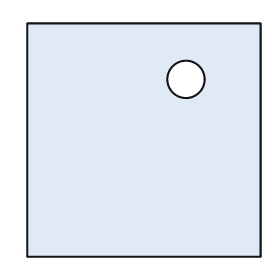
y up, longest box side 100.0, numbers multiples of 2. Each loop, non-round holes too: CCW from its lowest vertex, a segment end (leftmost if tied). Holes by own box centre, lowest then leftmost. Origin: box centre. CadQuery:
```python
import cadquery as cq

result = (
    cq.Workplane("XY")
    .moveTo(-50.0, -50.0)
    .lineTo(50.0, -50.0)
    .lineTo(50.0, 50.0)
    .lineTo(-50.0, 50.0)
    .close()
    .moveTo(18.0, 26.0)
    .circle(8.0)
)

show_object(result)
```